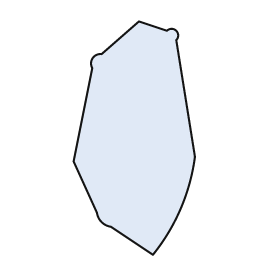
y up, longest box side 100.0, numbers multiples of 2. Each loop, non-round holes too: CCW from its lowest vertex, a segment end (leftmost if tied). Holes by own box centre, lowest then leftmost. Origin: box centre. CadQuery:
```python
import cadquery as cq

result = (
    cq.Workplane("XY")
    .moveTo(8.0, -50.0)
    .threePointArc((20.0, -30.0), (26.0, -8.0))
    .lineTo(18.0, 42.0)
    .threePointArc((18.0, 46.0), (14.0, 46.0))
    .lineTo(2.0, 50.0)
    .lineTo(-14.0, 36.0)
    .threePointArc((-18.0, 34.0), (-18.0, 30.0))
    .lineTo(-26.0, -10.0)
    .lineTo(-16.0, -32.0)
    .threePointArc((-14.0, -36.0), (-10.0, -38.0))
    .close()
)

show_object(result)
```